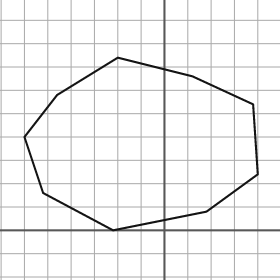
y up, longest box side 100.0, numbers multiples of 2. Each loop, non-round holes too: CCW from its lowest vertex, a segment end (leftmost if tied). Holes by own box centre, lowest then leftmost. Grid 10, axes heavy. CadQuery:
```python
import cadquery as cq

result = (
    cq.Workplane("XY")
    .moveTo(-22.0, 0.0)
    .lineTo(18.0, 8.0)
    .lineTo(40.0, 24.0)
    .lineTo(38.0, 54.0)
    .lineTo(12.0, 66.0)
    .lineTo(-20.0, 74.0)
    .lineTo(-46.0, 58.0)
    .lineTo(-60.0, 40.0)
    .lineTo(-52.0, 16.0)
    .close()
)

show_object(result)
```